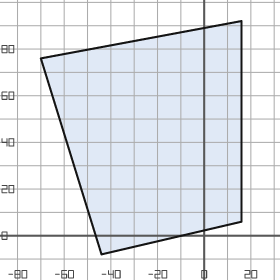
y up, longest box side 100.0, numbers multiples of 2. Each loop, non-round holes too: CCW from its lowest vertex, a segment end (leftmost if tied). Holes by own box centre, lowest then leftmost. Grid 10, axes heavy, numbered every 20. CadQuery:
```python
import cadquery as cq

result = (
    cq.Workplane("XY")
    .moveTo(-44.0, -8.0)
    .lineTo(16.0, 6.0)
    .lineTo(16.0, 92.0)
    .lineTo(-70.0, 76.0)
    .close()
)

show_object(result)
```